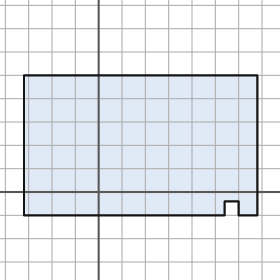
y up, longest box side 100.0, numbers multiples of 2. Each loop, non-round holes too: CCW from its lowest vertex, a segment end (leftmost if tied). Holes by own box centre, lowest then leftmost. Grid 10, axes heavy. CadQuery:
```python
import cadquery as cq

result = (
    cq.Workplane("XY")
    .moveTo(-32.0, -10.0)
    .lineTo(54.0, -10.0)
    .lineTo(54.0, -4.0)
    .lineTo(60.0, -4.0)
    .lineTo(60.0, -10.0)
    .lineTo(68.0, -10.0)
    .lineTo(68.0, 50.0)
    .lineTo(-32.0, 50.0)
    .close()
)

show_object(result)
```